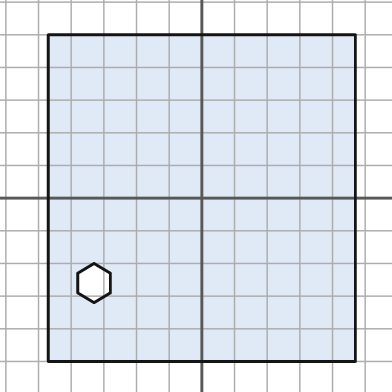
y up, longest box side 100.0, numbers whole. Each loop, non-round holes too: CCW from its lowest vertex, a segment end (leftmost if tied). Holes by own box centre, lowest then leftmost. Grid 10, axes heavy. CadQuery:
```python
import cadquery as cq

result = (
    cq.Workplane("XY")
    .moveTo(-47.0, -50.0)
    .lineTo(47.0, -50.0)
    .lineTo(47.0, 50.0)
    .lineTo(-47.0, 50.0)
    .close()
    .moveTo(-33.0, -32.0)
    .lineTo(-28.0, -29.0)
    .lineTo(-28.0, -23.0)
    .lineTo(-33.0, -20.0)
    .lineTo(-38.0, -23.0)
    .lineTo(-38.0, -29.0)
    .close()
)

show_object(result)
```